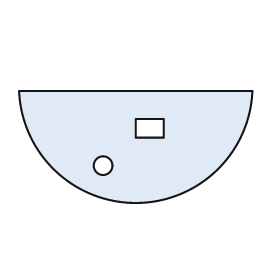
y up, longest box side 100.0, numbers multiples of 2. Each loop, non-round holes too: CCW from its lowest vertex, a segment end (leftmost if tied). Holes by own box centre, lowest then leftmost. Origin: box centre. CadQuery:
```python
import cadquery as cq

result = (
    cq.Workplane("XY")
    .moveTo(-50.0, 24.0)
    .threePointArc((0.0, -24.0), (50.0, 24.0))
    .close()
    .moveTo(-14.0, -8.0)
    .circle(4.0)
    .moveTo(0.0, 4.0)
    .lineTo(12.0, 4.0)
    .lineTo(12.0, 12.0)
    .lineTo(0.0, 12.0)
    .close()
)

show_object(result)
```